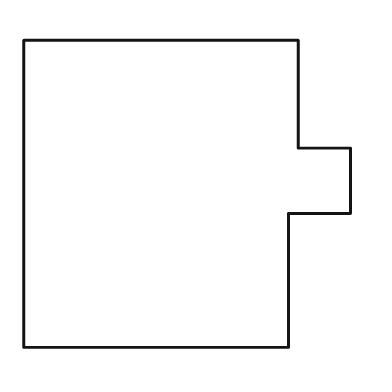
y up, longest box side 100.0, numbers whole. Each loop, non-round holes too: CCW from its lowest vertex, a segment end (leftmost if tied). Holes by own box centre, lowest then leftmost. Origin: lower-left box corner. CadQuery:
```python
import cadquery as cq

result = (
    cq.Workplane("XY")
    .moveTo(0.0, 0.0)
    .lineTo(81.0, 0.0)
    .lineTo(81.0, 41.0)
    .lineTo(100.0, 41.0)
    .lineTo(100.0, 61.0)
    .lineTo(84.0, 61.0)
    .lineTo(84.0, 94.0)
    .lineTo(0.0, 94.0)
    .close()
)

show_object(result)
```